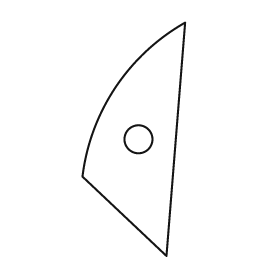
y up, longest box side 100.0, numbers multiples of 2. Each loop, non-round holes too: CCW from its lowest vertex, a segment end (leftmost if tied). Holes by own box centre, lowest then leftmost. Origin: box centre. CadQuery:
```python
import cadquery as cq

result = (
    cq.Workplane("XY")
    .moveTo(14.0, -50.0)
    .lineTo(22.0, 50.0)
    .threePointArc((-8.0, 22.0), (-22.0, -16.0))
    .close()
    .moveTo(2.0, 0.0)
    .circle(6.0)
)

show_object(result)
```